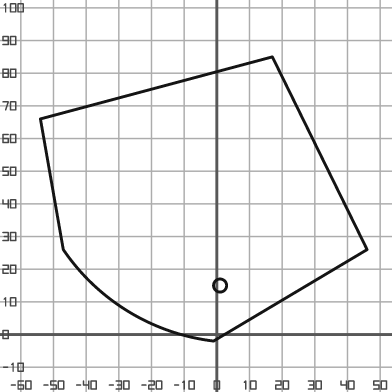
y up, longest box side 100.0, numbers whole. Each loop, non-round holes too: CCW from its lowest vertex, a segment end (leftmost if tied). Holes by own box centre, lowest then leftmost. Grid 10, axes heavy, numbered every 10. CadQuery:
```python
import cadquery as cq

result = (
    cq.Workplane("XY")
    .moveTo(-1.0, -2.0)
    .lineTo(46.0, 26.0)
    .lineTo(17.0, 85.0)
    .lineTo(-54.0, 66.0)
    .lineTo(-47.0, 26.0)
    .threePointArc((-27.0, 7.0), (-1.0, -2.0))
    .close()
    .moveTo(1.0, 15.0)
    .circle(2.0)
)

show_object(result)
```